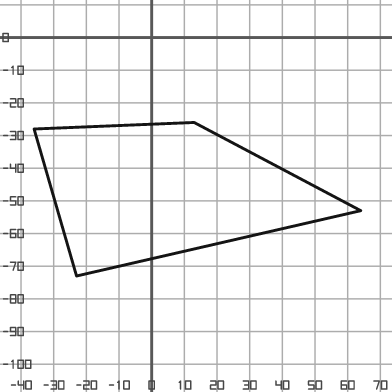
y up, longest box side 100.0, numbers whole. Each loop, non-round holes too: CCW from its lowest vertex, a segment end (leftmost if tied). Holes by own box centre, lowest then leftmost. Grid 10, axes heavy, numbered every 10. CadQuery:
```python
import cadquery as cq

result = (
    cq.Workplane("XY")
    .moveTo(-23.0, -73.0)
    .lineTo(64.0, -53.0)
    .lineTo(13.0, -26.0)
    .lineTo(-36.0, -28.0)
    .close()
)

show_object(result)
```